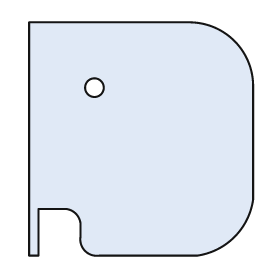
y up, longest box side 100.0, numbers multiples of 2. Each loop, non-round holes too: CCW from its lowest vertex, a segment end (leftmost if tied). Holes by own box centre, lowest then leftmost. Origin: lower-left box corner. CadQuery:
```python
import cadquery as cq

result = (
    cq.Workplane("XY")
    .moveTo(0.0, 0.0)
    .lineTo(4.0, 0.0)
    .lineTo(4.0, 20.0)
    .lineTo(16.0, 20.0)
    .threePointArc((20.0, 18.0), (22.0, 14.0))
    .lineTo(22.0, 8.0)
    .threePointArc((24.0, 2.0), (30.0, 0.0))
    .lineTo(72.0, 0.0)
    .threePointArc((88.0, 8.0), (96.0, 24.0))
    .lineTo(96.0, 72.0)
    .threePointArc((88.0, 92.0), (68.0, 100.0))
    .lineTo(0.0, 100.0)
    .close()
    .moveTo(28.0, 72.0)
    .circle(4.0)
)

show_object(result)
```